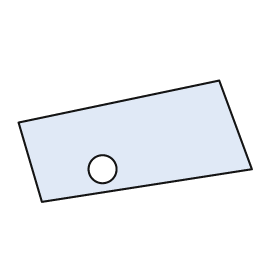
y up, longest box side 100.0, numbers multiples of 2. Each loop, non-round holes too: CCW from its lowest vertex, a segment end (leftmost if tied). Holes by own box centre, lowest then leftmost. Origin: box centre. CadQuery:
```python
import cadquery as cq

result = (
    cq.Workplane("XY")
    .moveTo(-40.0, -26.0)
    .lineTo(50.0, -12.0)
    .lineTo(36.0, 26.0)
    .lineTo(-50.0, 8.0)
    .close()
    .moveTo(-14.0, -12.0)
    .circle(6.0)
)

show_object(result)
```